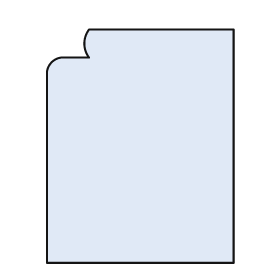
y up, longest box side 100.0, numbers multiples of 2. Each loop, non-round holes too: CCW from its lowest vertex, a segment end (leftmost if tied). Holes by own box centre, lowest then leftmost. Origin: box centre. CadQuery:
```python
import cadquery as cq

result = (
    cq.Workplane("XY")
    .moveTo(-40.0, -50.0)
    .lineTo(40.0, -50.0)
    .lineTo(40.0, 50.0)
    .lineTo(-22.0, 50.0)
    .threePointArc((-24.0, 44.0), (-22.0, 38.0))
    .lineTo(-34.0, 38.0)
    .threePointArc((-38.0, 36.0), (-40.0, 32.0))
    .close()
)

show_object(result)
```